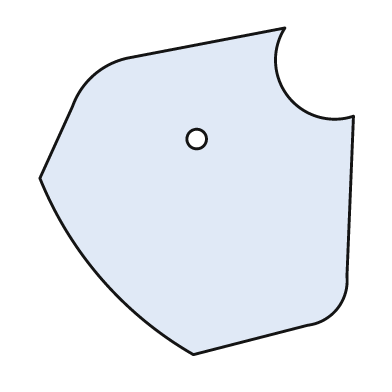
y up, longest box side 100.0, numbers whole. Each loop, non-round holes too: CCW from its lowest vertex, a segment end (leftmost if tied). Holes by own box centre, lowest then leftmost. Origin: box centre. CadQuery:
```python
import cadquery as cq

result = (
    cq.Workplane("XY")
    .moveTo(-1.0, -50.0)
    .lineTo(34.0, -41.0)
    .threePointArc((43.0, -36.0), (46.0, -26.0))
    .lineTo(48.0, 23.0)
    .threePointArc((28.0, 29.0), (27.0, 50.0))
    .lineTo(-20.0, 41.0)
    .threePointArc((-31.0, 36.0), (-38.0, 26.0))
    .lineTo(-48.0, 4.0)
    .threePointArc((-29.0, -27.0), (-1.0, -50.0))
    .close()
    .moveTo(0.0, 16.0)
    .circle(3.0)
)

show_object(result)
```